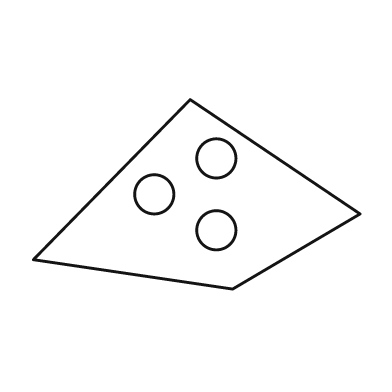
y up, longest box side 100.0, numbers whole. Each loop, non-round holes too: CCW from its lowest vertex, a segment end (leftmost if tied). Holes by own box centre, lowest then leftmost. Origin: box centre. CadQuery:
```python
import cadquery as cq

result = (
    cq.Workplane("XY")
    .moveTo(11.0, -29.0)
    .lineTo(50.0, -6.0)
    .lineTo(-2.0, 29.0)
    .lineTo(-50.0, -20.0)
    .close()
    .moveTo(6.0, -11.0)
    .circle(6.0)
    .moveTo(-13.0, 0.0)
    .circle(6.0)
    .moveTo(6.0, 11.0)
    .circle(6.0)
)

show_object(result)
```